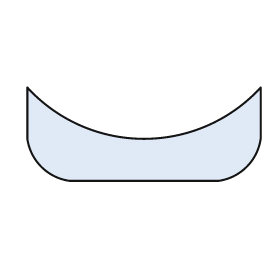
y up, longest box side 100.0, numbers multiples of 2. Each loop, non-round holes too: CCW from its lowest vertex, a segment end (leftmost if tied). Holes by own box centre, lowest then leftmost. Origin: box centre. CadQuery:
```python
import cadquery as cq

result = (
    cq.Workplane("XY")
    .moveTo(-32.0, -20.0)
    .lineTo(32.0, -20.0)
    .threePointArc((44.0, -14.0), (50.0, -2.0))
    .lineTo(50.0, 20.0)
    .threePointArc((0.0, -2.0), (-50.0, 20.0))
    .lineTo(-50.0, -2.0)
    .threePointArc((-44.0, -14.0), (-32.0, -20.0))
    .close()
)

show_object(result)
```